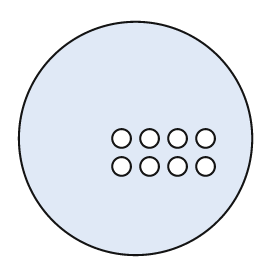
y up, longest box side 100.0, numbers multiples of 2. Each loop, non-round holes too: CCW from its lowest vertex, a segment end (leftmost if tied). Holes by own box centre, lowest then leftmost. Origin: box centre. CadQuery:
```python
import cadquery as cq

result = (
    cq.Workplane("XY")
    .moveTo(0.0, 0.0)
    .circle(50.0)
    .moveTo(-6.0, -12.0)
    .circle(4.0)
    .moveTo(6.0, -12.0)
    .circle(4.0)
    .moveTo(18.0, -12.0)
    .circle(4.0)
    .moveTo(30.0, -12.0)
    .circle(4.0)
    .moveTo(-6.0, 0.0)
    .circle(4.0)
    .moveTo(6.0, 0.0)
    .circle(4.0)
    .moveTo(18.0, 0.0)
    .circle(4.0)
    .moveTo(30.0, 0.0)
    .circle(4.0)
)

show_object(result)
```